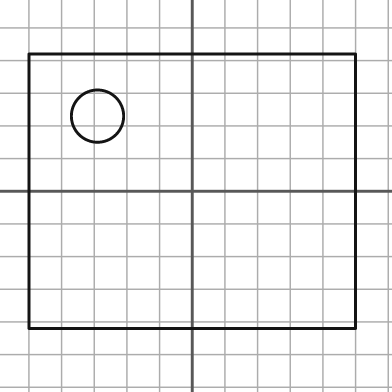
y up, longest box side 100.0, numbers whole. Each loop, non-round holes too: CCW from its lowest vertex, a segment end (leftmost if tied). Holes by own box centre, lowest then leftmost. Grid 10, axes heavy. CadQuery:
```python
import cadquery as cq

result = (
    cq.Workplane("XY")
    .moveTo(-50.0, -42.0)
    .lineTo(50.0, -42.0)
    .lineTo(50.0, 42.0)
    .lineTo(-50.0, 42.0)
    .close()
    .moveTo(-29.0, 23.0)
    .circle(8.0)
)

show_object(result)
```